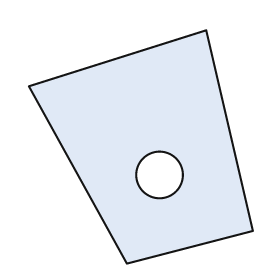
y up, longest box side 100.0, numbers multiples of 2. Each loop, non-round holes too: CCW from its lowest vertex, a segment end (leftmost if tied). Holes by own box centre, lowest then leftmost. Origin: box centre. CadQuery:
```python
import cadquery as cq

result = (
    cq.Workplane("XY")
    .moveTo(-6.0, -50.0)
    .lineTo(48.0, -36.0)
    .lineTo(28.0, 50.0)
    .lineTo(-48.0, 26.0)
    .close()
    .moveTo(8.0, -12.0)
    .circle(10.0)
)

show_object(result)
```